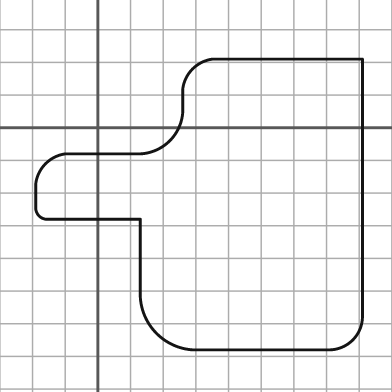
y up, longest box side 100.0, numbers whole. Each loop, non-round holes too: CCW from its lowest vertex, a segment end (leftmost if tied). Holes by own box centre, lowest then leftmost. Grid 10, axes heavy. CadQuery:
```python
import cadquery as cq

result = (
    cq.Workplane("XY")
    .moveTo(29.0, -68.0)
    .lineTo(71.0, -68.0)
    .threePointArc((78.0, -65.0), (81.0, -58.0))
    .lineTo(81.0, 21.0)
    .lineTo(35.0, 21.0)
    .threePointArc((29.0, 18.0), (26.0, 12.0))
    .lineTo(26.0, 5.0)
    .threePointArc((22.0, -4.0), (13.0, -8.0))
    .lineTo(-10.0, -8.0)
    .threePointArc((-16.0, -11.0), (-19.0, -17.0))
    .lineTo(-19.0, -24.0)
    .threePointArc((-18.0, -27.0), (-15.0, -28.0))
    .lineTo(13.0, -28.0)
    .lineTo(13.0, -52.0)
    .threePointArc((18.0, -63.0), (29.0, -68.0))
    .close()
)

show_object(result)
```